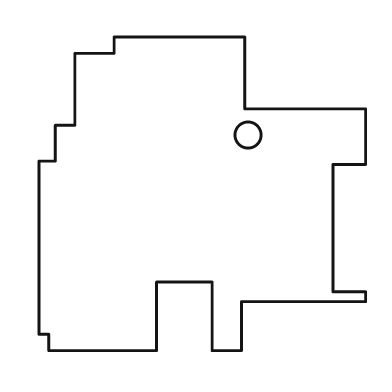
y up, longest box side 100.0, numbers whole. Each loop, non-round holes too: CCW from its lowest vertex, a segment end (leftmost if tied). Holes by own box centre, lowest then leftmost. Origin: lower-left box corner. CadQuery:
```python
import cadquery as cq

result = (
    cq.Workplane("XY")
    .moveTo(3.0, 0.0)
    .lineTo(36.0, 0.0)
    .lineTo(36.0, 21.0)
    .lineTo(53.0, 21.0)
    .lineTo(53.0, 0.0)
    .lineTo(62.0, 0.0)
    .lineTo(62.0, 15.0)
    .lineTo(100.0, 15.0)
    .lineTo(100.0, 18.0)
    .lineTo(90.0, 18.0)
    .lineTo(90.0, 57.0)
    .lineTo(100.0, 57.0)
    .lineTo(100.0, 74.0)
    .lineTo(63.0, 74.0)
    .lineTo(63.0, 96.0)
    .lineTo(23.0, 96.0)
    .lineTo(23.0, 91.0)
    .lineTo(11.0, 91.0)
    .lineTo(11.0, 69.0)
    .lineTo(5.0, 69.0)
    .lineTo(5.0, 58.0)
    .lineTo(0.0, 58.0)
    .lineTo(0.0, 5.0)
    .lineTo(3.0, 5.0)
    .close()
    .moveTo(64.0, 66.0)
    .circle(4.0)
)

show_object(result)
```